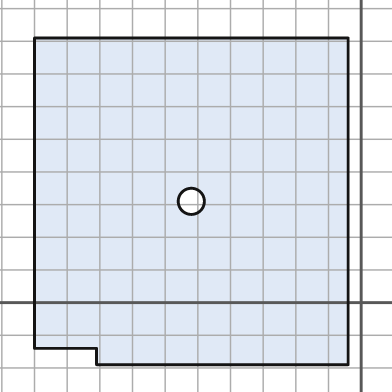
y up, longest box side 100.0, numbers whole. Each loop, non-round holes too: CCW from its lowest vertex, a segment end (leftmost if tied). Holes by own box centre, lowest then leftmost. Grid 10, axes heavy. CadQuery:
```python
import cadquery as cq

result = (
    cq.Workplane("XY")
    .moveTo(-81.0, -19.0)
    .lineTo(-4.0, -19.0)
    .lineTo(-4.0, 81.0)
    .lineTo(-100.0, 81.0)
    .lineTo(-100.0, -14.0)
    .lineTo(-81.0, -14.0)
    .close()
    .moveTo(-52.0, 31.0)
    .circle(4.0)
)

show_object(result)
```